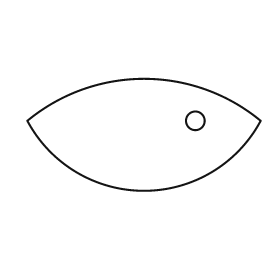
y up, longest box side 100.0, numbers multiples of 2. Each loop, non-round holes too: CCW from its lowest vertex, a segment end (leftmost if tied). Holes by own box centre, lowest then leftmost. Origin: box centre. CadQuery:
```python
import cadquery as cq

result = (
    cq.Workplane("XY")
    .moveTo(-50.0, 6.0)
    .threePointArc((0.0, -24.0), (50.0, 6.0))
    .threePointArc((0.0, 24.0), (-50.0, 6.0))
    .close()
    .moveTo(22.0, 6.0)
    .circle(4.0)
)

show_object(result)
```